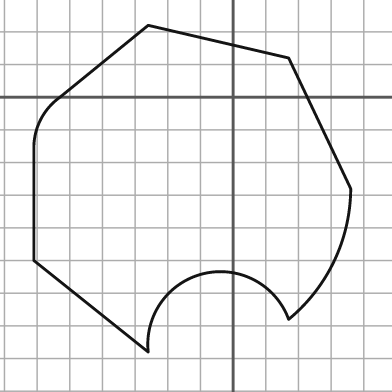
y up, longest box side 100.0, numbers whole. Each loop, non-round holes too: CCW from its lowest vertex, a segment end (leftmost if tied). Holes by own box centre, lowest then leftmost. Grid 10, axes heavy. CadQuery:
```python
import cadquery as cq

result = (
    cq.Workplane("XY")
    .moveTo(-26.0, -78.0)
    .threePointArc((-9.0, -54.0), (17.0, -68.0))
    .threePointArc((31.0, -50.0), (36.0, -28.0))
    .lineTo(17.0, 12.0)
    .lineTo(-26.0, 22.0)
    .lineTo(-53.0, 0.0)
    .threePointArc((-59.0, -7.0), (-61.0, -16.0))
    .lineTo(-61.0, -50.0)
    .close()
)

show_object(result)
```